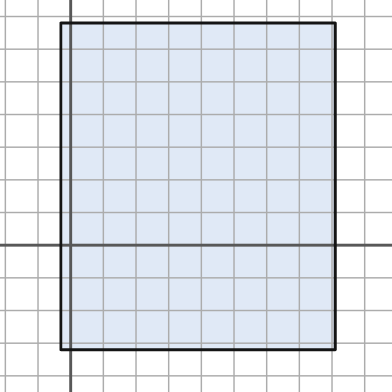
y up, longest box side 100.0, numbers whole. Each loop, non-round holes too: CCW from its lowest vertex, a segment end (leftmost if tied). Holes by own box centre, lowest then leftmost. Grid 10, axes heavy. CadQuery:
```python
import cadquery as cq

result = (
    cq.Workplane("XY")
    .moveTo(-3.0, -32.0)
    .lineTo(81.0, -32.0)
    .lineTo(81.0, 68.0)
    .lineTo(-3.0, 68.0)
    .close()
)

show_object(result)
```